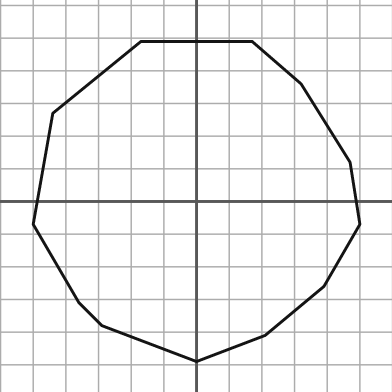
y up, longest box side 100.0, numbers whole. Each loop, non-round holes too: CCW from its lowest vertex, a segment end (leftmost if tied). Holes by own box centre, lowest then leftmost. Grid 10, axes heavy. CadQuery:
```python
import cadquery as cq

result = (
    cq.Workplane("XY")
    .moveTo(0.0, -49.0)
    .lineTo(21.0, -41.0)
    .lineTo(39.0, -26.0)
    .lineTo(50.0, -7.0)
    .lineTo(47.0, 12.0)
    .lineTo(32.0, 36.0)
    .lineTo(17.0, 49.0)
    .lineTo(-17.0, 49.0)
    .lineTo(-44.0, 27.0)
    .lineTo(-50.0, -7.0)
    .lineTo(-36.0, -31.0)
    .lineTo(-29.0, -38.0)
    .close()
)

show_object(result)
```